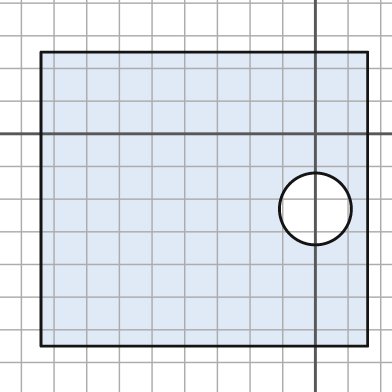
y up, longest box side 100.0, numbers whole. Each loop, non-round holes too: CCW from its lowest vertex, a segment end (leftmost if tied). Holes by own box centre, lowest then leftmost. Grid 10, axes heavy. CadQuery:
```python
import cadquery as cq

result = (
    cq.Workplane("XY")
    .moveTo(-84.0, -65.0)
    .lineTo(16.0, -65.0)
    .lineTo(16.0, 25.0)
    .lineTo(-84.0, 25.0)
    .close()
    .moveTo(0.0, -23.0)
    .circle(11.0)
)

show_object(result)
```